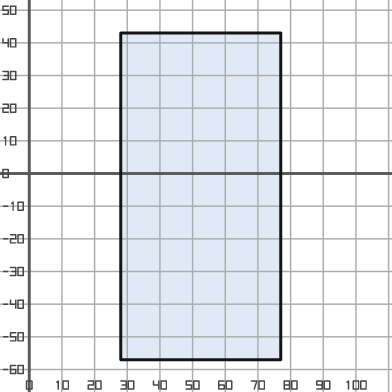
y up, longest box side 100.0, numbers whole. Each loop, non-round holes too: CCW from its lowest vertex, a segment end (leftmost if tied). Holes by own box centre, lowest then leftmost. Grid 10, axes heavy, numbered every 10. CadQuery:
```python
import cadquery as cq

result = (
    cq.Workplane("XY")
    .moveTo(28.0, -57.0)
    .lineTo(77.0, -57.0)
    .lineTo(77.0, 43.0)
    .lineTo(28.0, 43.0)
    .close()
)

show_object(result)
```